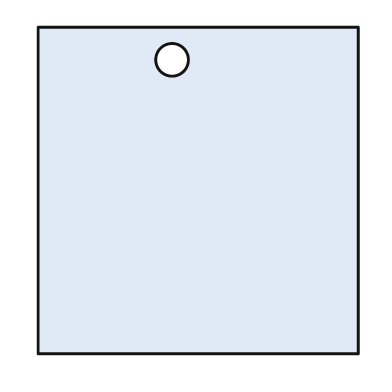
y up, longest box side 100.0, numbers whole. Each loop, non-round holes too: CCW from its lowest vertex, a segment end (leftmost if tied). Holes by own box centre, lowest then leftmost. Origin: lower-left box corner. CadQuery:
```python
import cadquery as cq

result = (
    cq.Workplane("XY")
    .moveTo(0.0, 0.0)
    .lineTo(98.0, 0.0)
    .lineTo(98.0, 100.0)
    .lineTo(0.0, 100.0)
    .close()
    .moveTo(41.0, 90.0)
    .circle(5.0)
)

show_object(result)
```